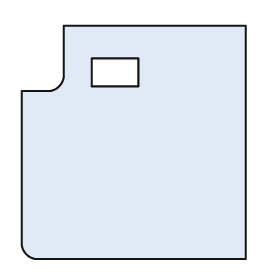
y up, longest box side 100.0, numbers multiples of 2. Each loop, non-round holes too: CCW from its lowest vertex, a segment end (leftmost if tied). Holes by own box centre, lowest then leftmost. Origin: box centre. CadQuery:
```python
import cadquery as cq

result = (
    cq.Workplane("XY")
    .moveTo(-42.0, -50.0)
    .lineTo(48.0, -50.0)
    .lineTo(48.0, 50.0)
    .lineTo(-30.0, 50.0)
    .lineTo(-30.0, 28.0)
    .threePointArc((-32.0, 24.0), (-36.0, 22.0))
    .lineTo(-48.0, 22.0)
    .lineTo(-48.0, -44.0)
    .threePointArc((-46.0, -48.0), (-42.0, -50.0))
    .close()
    .moveTo(-18.0, 24.0)
    .lineTo(2.0, 24.0)
    .lineTo(2.0, 36.0)
    .lineTo(-18.0, 36.0)
    .close()
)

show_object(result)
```